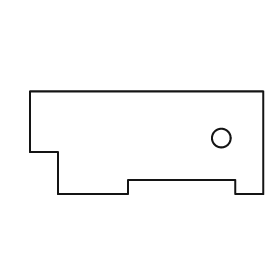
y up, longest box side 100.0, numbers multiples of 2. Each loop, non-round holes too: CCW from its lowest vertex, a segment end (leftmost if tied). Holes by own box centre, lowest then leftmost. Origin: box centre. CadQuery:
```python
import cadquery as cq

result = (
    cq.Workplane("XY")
    .moveTo(-38.0, -22.0)
    .lineTo(-8.0, -22.0)
    .lineTo(-8.0, -16.0)
    .lineTo(38.0, -16.0)
    .lineTo(38.0, -22.0)
    .lineTo(50.0, -22.0)
    .lineTo(50.0, 22.0)
    .lineTo(-50.0, 22.0)
    .lineTo(-50.0, -4.0)
    .lineTo(-38.0, -4.0)
    .close()
    .moveTo(32.0, 2.0)
    .circle(4.0)
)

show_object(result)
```